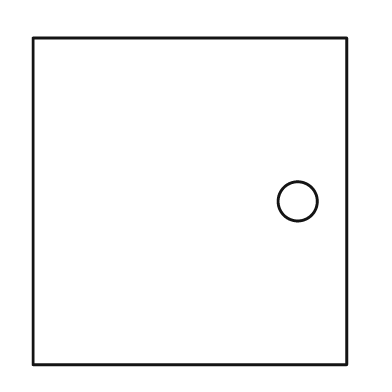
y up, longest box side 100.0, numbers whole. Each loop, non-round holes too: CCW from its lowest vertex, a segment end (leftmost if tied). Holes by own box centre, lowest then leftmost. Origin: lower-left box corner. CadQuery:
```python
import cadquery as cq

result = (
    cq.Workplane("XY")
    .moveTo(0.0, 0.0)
    .lineTo(96.0, 0.0)
    .lineTo(96.0, 100.0)
    .lineTo(0.0, 100.0)
    .close()
    .moveTo(81.0, 50.0)
    .circle(6.0)
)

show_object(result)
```